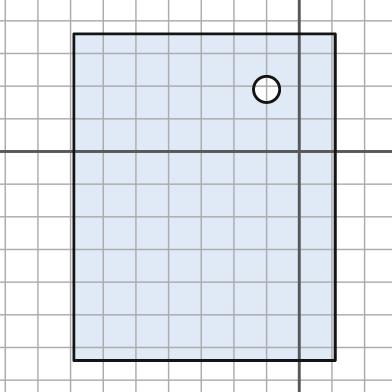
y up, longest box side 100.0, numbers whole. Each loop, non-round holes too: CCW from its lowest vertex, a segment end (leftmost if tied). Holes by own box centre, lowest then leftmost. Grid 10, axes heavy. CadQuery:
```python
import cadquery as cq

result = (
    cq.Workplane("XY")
    .moveTo(-69.0, -64.0)
    .lineTo(11.0, -64.0)
    .lineTo(11.0, 36.0)
    .lineTo(-69.0, 36.0)
    .close()
    .moveTo(-10.0, 19.0)
    .circle(4.0)
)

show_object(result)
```